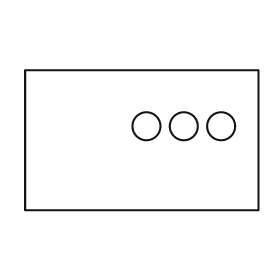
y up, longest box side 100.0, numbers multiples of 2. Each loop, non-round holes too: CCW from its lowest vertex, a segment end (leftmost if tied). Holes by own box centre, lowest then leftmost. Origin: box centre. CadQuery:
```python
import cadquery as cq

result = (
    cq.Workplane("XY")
    .moveTo(-50.0, -30.0)
    .lineTo(50.0, -30.0)
    .lineTo(50.0, 30.0)
    .lineTo(-50.0, 30.0)
    .close()
    .moveTo(2.0, 6.0)
    .circle(6.0)
    .moveTo(18.0, 6.0)
    .circle(6.0)
    .moveTo(34.0, 6.0)
    .circle(6.0)
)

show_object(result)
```